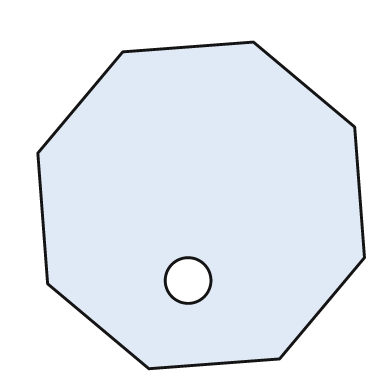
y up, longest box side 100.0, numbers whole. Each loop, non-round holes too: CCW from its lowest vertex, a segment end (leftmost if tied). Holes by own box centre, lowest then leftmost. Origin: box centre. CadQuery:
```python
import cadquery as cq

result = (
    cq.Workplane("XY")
    .moveTo(-16.0, -50.0)
    .lineTo(24.0, -47.0)
    .lineTo(50.0, -16.0)
    .lineTo(47.0, 24.0)
    .lineTo(16.0, 50.0)
    .lineTo(-24.0, 47.0)
    .lineTo(-50.0, 16.0)
    .lineTo(-47.0, -24.0)
    .close()
    .moveTo(-4.0, -23.0)
    .circle(7.0)
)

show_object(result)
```